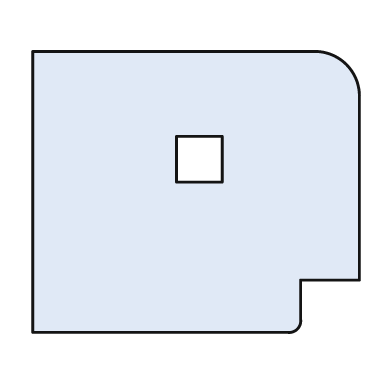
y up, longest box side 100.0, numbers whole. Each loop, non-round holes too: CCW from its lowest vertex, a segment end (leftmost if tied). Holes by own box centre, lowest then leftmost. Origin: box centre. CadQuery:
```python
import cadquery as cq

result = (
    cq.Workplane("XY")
    .moveTo(-50.0, -43.0)
    .lineTo(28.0, -43.0)
    .threePointArc((31.0, -42.0), (32.0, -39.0))
    .lineTo(32.0, -27.0)
    .lineTo(50.0, -27.0)
    .lineTo(50.0, 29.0)
    .threePointArc((46.0, 39.0), (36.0, 43.0))
    .lineTo(-50.0, 43.0)
    .close()
    .moveTo(-6.0, 3.0)
    .lineTo(8.0, 3.0)
    .lineTo(8.0, 17.0)
    .lineTo(-6.0, 17.0)
    .close()
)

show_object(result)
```